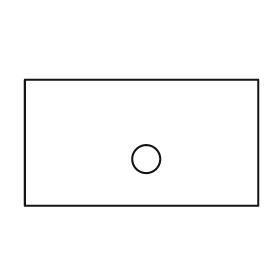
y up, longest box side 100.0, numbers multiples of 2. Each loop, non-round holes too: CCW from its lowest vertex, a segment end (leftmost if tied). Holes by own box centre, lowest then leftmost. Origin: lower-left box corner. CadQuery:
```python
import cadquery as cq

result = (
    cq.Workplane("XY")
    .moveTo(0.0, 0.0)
    .lineTo(100.0, 0.0)
    .lineTo(100.0, 54.0)
    .lineTo(0.0, 54.0)
    .close()
    .moveTo(52.0, 20.0)
    .circle(6.0)
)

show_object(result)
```